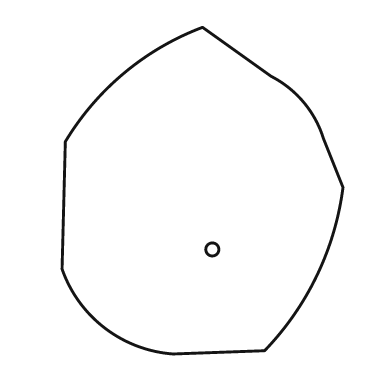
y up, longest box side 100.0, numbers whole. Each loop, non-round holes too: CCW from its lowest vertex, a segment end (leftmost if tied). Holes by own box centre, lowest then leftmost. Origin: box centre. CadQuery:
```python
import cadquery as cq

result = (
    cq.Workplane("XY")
    .moveTo(-9.0, -50.0)
    .lineTo(19.0, -49.0)
    .threePointArc((35.0, -26.0), (43.0, 1.0))
    .lineTo(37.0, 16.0)
    .threePointArc((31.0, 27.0), (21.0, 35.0))
    .lineTo(0.0, 50.0)
    .threePointArc((-24.0, 36.0), (-42.0, 15.0))
    .lineTo(-43.0, -24.0)
    .threePointArc((-30.0, -42.0), (-9.0, -50.0))
    .close()
    .moveTo(3.0, -18.0)
    .circle(2.0)
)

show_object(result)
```